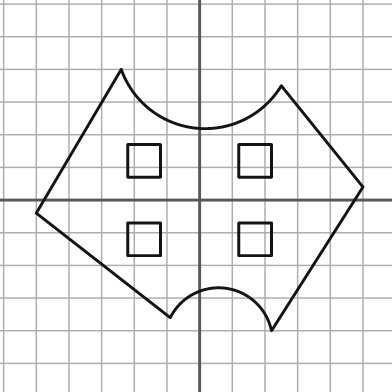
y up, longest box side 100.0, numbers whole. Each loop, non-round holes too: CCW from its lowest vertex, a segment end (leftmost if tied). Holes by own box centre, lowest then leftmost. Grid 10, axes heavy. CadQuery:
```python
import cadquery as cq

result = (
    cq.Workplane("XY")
    .moveTo(22.0, -40.0)
    .lineTo(50.0, 4.0)
    .lineTo(25.0, 35.0)
    .threePointArc((-1.0, 22.0), (-24.0, 40.0))
    .lineTo(-50.0, -4.0)
    .lineTo(-9.0, -36.0)
    .threePointArc((8.0, -27.0), (22.0, -40.0))
    .close()
    .moveTo(-22.0, -17.0)
    .lineTo(-12.0, -17.0)
    .lineTo(-12.0, -7.0)
    .lineTo(-22.0, -7.0)
    .close()
    .moveTo(12.0, -17.0)
    .lineTo(22.0, -17.0)
    .lineTo(22.0, -7.0)
    .lineTo(12.0, -7.0)
    .close()
    .moveTo(-22.0, 7.0)
    .lineTo(-12.0, 7.0)
    .lineTo(-12.0, 17.0)
    .lineTo(-22.0, 17.0)
    .close()
    .moveTo(12.0, 7.0)
    .lineTo(22.0, 7.0)
    .lineTo(22.0, 17.0)
    .lineTo(12.0, 17.0)
    .close()
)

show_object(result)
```